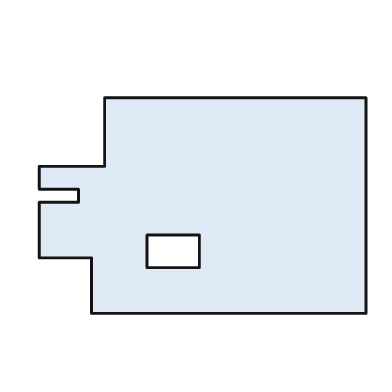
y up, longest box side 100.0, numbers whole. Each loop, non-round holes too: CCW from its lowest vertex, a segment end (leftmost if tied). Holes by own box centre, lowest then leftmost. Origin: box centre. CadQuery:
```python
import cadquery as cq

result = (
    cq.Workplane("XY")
    .moveTo(-34.0, -33.0)
    .lineTo(50.0, -33.0)
    .lineTo(50.0, 33.0)
    .lineTo(-30.0, 33.0)
    .lineTo(-30.0, 12.0)
    .lineTo(-50.0, 12.0)
    .lineTo(-50.0, 5.0)
    .lineTo(-38.0, 5.0)
    .lineTo(-38.0, 1.0)
    .lineTo(-50.0, 1.0)
    .lineTo(-50.0, -16.0)
    .lineTo(-34.0, -16.0)
    .close()
    .moveTo(-17.0, -19.0)
    .lineTo(-1.0, -19.0)
    .lineTo(-1.0, -9.0)
    .lineTo(-17.0, -9.0)
    .close()
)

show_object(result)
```